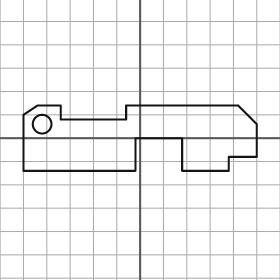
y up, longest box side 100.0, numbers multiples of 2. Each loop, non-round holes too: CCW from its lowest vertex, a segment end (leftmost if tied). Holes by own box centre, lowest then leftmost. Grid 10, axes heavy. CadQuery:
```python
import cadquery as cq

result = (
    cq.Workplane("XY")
    .moveTo(-50.0, -14.0)
    .lineTo(-2.0, -14.0)
    .lineTo(-2.0, 0.0)
    .lineTo(18.0, 0.0)
    .lineTo(18.0, -14.0)
    .lineTo(38.0, -14.0)
    .lineTo(38.0, -8.0)
    .lineTo(50.0, -8.0)
    .lineTo(50.0, 6.0)
    .lineTo(42.0, 14.0)
    .lineTo(-6.0, 14.0)
    .lineTo(-6.0, 8.0)
    .lineTo(-34.0, 8.0)
    .lineTo(-34.0, 14.0)
    .lineTo(-44.0, 14.0)
    .lineTo(-50.0, 10.0)
    .close()
    .moveTo(-42.0, 6.0)
    .circle(4.0)
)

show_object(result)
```